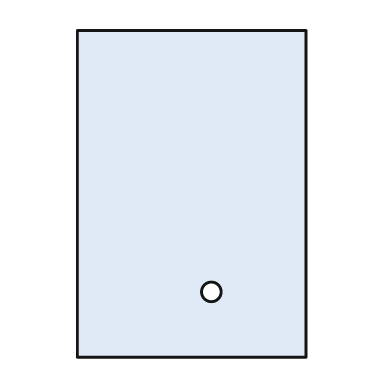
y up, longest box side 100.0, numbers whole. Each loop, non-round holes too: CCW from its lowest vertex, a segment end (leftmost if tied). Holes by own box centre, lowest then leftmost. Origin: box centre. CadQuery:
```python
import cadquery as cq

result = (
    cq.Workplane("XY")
    .moveTo(-35.0, -50.0)
    .lineTo(35.0, -50.0)
    .lineTo(35.0, 50.0)
    .lineTo(-35.0, 50.0)
    .close()
    .moveTo(6.0, -30.0)
    .circle(3.0)
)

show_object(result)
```